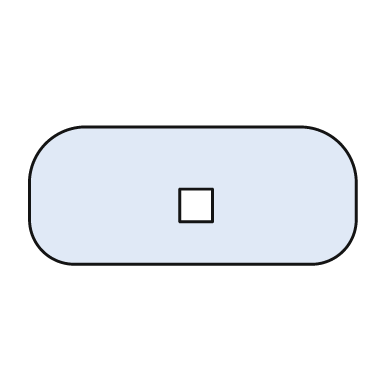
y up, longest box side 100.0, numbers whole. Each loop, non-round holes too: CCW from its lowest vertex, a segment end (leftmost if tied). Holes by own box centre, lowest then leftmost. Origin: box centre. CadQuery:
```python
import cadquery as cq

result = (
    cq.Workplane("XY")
    .moveTo(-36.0, -21.0)
    .lineTo(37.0, -21.0)
    .threePointArc((46.0, -17.0), (50.0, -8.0))
    .lineTo(50.0, 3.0)
    .threePointArc((45.0, 16.0), (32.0, 21.0))
    .lineTo(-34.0, 21.0)
    .threePointArc((-45.0, 16.0), (-50.0, 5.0))
    .lineTo(-50.0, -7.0)
    .threePointArc((-46.0, -17.0), (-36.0, -21.0))
    .close()
    .moveTo(-4.0, -8.0)
    .lineTo(6.0, -8.0)
    .lineTo(6.0, 2.0)
    .lineTo(-4.0, 2.0)
    .close()
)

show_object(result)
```